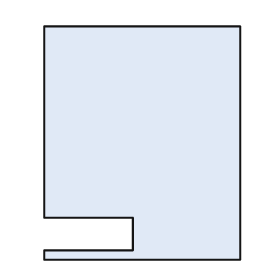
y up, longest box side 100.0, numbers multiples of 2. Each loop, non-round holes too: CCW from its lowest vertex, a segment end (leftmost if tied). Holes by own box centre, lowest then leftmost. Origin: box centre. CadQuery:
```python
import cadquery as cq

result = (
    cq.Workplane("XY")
    .moveTo(-42.0, -50.0)
    .lineTo(42.0, -50.0)
    .lineTo(42.0, 50.0)
    .lineTo(-42.0, 50.0)
    .lineTo(-42.0, -32.0)
    .lineTo(-4.0, -32.0)
    .lineTo(-4.0, -46.0)
    .lineTo(-42.0, -46.0)
    .close()
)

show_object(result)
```